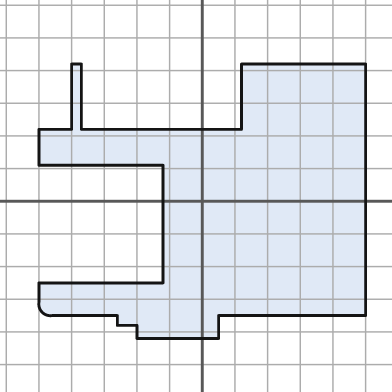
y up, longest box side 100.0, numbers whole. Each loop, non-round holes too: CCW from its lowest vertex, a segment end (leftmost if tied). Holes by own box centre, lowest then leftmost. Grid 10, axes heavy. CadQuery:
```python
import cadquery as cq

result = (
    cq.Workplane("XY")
    .moveTo(-20.0, -42.0)
    .lineTo(5.0, -42.0)
    .lineTo(5.0, -35.0)
    .lineTo(50.0, -35.0)
    .lineTo(50.0, 42.0)
    .lineTo(12.0, 42.0)
    .lineTo(12.0, 22.0)
    .lineTo(-37.0, 22.0)
    .lineTo(-37.0, 42.0)
    .lineTo(-40.0, 42.0)
    .lineTo(-40.0, 22.0)
    .lineTo(-50.0, 22.0)
    .lineTo(-50.0, 11.0)
    .lineTo(-12.0, 11.0)
    .lineTo(-12.0, -25.0)
    .lineTo(-50.0, -25.0)
    .lineTo(-50.0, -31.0)
    .threePointArc((-49.0, -34.0), (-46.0, -35.0))
    .lineTo(-26.0, -35.0)
    .lineTo(-26.0, -38.0)
    .lineTo(-20.0, -38.0)
    .close()
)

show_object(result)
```